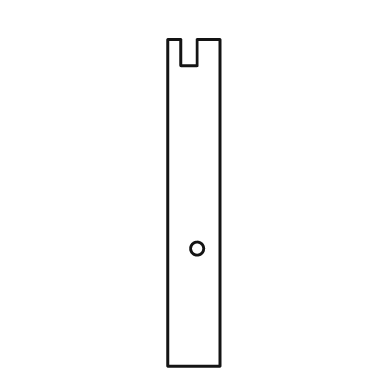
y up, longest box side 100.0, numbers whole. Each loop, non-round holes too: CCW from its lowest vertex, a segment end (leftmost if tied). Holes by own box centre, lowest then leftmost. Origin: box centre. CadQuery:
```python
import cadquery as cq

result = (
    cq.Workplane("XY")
    .moveTo(-8.0, -50.0)
    .lineTo(8.0, -50.0)
    .lineTo(8.0, 50.0)
    .lineTo(1.0, 50.0)
    .lineTo(1.0, 42.0)
    .lineTo(-4.0, 42.0)
    .lineTo(-4.0, 50.0)
    .lineTo(-8.0, 50.0)
    .close()
    .moveTo(1.0, -14.0)
    .circle(2.0)
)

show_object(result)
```